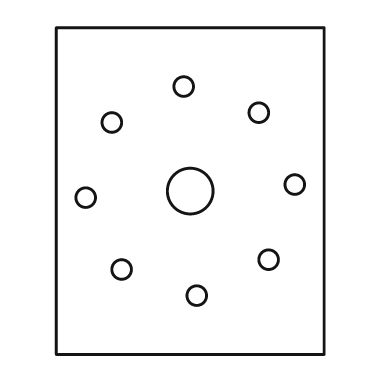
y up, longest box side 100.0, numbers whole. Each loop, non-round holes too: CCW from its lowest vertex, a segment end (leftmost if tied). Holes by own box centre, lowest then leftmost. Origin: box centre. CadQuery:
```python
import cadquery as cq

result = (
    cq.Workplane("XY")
    .moveTo(-41.0, -50.0)
    .lineTo(41.0, -50.0)
    .lineTo(41.0, 50.0)
    .lineTo(-41.0, 50.0)
    .close()
    .moveTo(2.0, -32.0)
    .circle(3.0)
    .moveTo(-21.0, -24.0)
    .circle(3.0)
    .moveTo(24.0, -21.0)
    .circle(3.0)
    .moveTo(-32.0, -2.0)
    .circle(3.0)
    .moveTo(0.0, 0.0)
    .circle(7.0)
    .moveTo(32.0, 2.0)
    .circle(3.0)
    .moveTo(-24.0, 21.0)
    .circle(3.0)
    .moveTo(21.0, 24.0)
    .circle(3.0)
    .moveTo(-2.0, 32.0)
    .circle(3.0)
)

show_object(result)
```